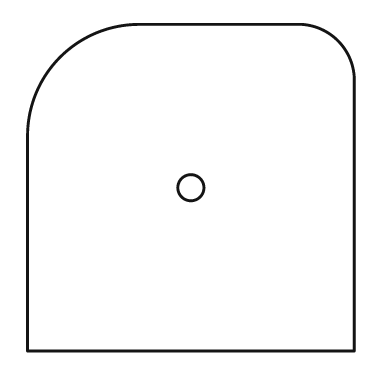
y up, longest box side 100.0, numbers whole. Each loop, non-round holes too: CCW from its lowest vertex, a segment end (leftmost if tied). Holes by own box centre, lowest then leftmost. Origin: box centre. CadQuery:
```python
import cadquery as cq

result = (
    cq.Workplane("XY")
    .moveTo(-50.0, -50.0)
    .lineTo(50.0, -50.0)
    .lineTo(50.0, 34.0)
    .threePointArc((45.0, 45.0), (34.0, 50.0))
    .lineTo(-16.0, 50.0)
    .threePointArc((-40.0, 40.0), (-50.0, 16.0))
    .close()
    .moveTo(0.0, 0.0)
    .circle(4.0)
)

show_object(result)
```